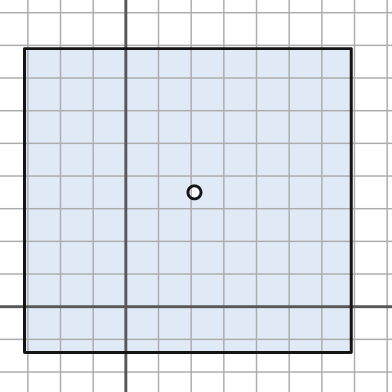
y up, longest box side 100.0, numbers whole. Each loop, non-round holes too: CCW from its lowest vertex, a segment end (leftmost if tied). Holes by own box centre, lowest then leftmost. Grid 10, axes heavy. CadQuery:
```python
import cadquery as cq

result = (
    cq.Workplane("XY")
    .moveTo(-31.0, -14.0)
    .lineTo(69.0, -14.0)
    .lineTo(69.0, 79.0)
    .lineTo(-31.0, 79.0)
    .close()
    .moveTo(21.0, 35.0)
    .circle(2.0)
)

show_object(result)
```